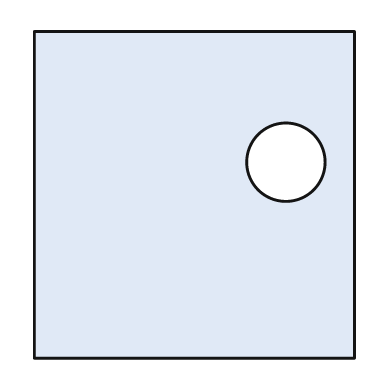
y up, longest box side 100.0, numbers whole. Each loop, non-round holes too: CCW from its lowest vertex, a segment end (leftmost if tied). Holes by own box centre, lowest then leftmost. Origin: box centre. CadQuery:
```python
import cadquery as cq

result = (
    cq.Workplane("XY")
    .moveTo(-49.0, -50.0)
    .lineTo(49.0, -50.0)
    .lineTo(49.0, 50.0)
    .lineTo(-49.0, 50.0)
    .close()
    .moveTo(28.0, 10.0)
    .circle(12.0)
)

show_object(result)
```